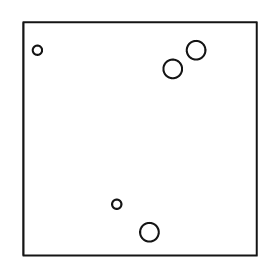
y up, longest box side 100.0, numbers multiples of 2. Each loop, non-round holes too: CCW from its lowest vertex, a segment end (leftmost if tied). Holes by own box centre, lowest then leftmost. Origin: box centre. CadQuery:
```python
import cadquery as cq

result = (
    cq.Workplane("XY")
    .moveTo(-50.0, -50.0)
    .lineTo(50.0, -50.0)
    .lineTo(50.0, 50.0)
    .lineTo(-50.0, 50.0)
    .close()
    .moveTo(4.0, -40.0)
    .circle(4.0)
    .moveTo(-10.0, -28.0)
    .circle(2.0)
    .moveTo(14.0, 30.0)
    .circle(4.0)
    .moveTo(-44.0, 38.0)
    .circle(2.0)
    .moveTo(24.0, 38.0)
    .circle(4.0)
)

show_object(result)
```